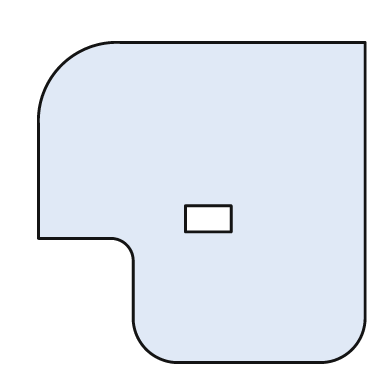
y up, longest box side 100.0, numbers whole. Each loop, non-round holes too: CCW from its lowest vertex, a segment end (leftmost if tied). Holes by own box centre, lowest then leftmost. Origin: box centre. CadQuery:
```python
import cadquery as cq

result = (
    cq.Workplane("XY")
    .moveTo(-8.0, -49.0)
    .lineTo(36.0, -49.0)
    .threePointArc((46.0, -45.0), (50.0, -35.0))
    .lineTo(50.0, 49.0)
    .lineTo(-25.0, 49.0)
    .threePointArc((-43.0, 42.0), (-50.0, 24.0))
    .lineTo(-50.0, -11.0)
    .lineTo(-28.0, -11.0)
    .threePointArc((-23.0, -13.0), (-21.0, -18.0))
    .lineTo(-21.0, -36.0)
    .threePointArc((-17.0, -45.0), (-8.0, -49.0))
    .close()
    .moveTo(-5.0, -9.0)
    .lineTo(9.0, -9.0)
    .lineTo(9.0, -1.0)
    .lineTo(-5.0, -1.0)
    .close()
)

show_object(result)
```